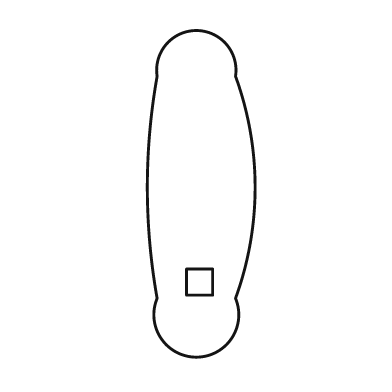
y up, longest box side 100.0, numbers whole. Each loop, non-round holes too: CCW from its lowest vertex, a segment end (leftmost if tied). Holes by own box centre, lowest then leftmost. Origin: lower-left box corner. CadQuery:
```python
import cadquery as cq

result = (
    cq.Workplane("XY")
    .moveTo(3.0, 18.0)
    .threePointArc((15.0, 0.0), (27.0, 18.0))
    .threePointArc((33.0, 52.0), (27.0, 86.0))
    .threePointArc((15.0, 100.0), (3.0, 86.0))
    .threePointArc((0.0, 52.0), (3.0, 18.0))
    .close()
    .moveTo(12.0, 19.0)
    .lineTo(20.0, 19.0)
    .lineTo(20.0, 27.0)
    .lineTo(12.0, 27.0)
    .close()
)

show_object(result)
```